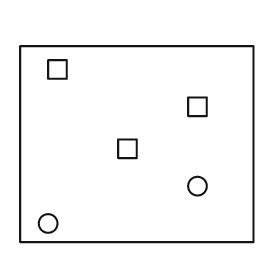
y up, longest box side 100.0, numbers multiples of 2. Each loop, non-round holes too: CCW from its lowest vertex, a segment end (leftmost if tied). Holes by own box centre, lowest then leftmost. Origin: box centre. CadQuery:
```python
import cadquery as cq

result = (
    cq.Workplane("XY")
    .moveTo(-50.0, -42.0)
    .lineTo(50.0, -42.0)
    .lineTo(50.0, 42.0)
    .lineTo(-50.0, 42.0)
    .close()
    .moveTo(-38.0, -34.0)
    .circle(4.0)
    .moveTo(26.0, -18.0)
    .circle(4.0)
    .moveTo(-8.0, -6.0)
    .lineTo(0.0, -6.0)
    .lineTo(0.0, 2.0)
    .lineTo(-8.0, 2.0)
    .close()
    .moveTo(22.0, 12.0)
    .lineTo(30.0, 12.0)
    .lineTo(30.0, 20.0)
    .lineTo(22.0, 20.0)
    .close()
    .moveTo(-38.0, 28.0)
    .lineTo(-30.0, 28.0)
    .lineTo(-30.0, 36.0)
    .lineTo(-38.0, 36.0)
    .close()
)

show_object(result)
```